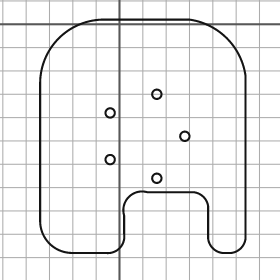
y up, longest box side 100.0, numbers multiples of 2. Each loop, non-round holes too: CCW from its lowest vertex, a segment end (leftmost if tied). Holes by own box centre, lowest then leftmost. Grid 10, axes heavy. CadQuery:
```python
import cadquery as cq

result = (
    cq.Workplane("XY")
    .moveTo(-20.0, -98.0)
    .lineTo(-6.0, -98.0)
    .threePointArc((0.0, -96.0), (2.0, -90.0))
    .lineTo(2.0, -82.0)
    .threePointArc((4.0, -74.0), (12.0, -72.0))
    .lineTo(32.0, -72.0)
    .threePointArc((36.0, -74.0), (38.0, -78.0))
    .lineTo(38.0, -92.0)
    .threePointArc((40.0, -96.0), (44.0, -98.0))
    .lineTo(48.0, -98.0)
    .threePointArc((52.0, -96.0), (54.0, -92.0))
    .lineTo(54.0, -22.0)
    .threePointArc((46.0, -6.0), (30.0, 2.0))
    .lineTo(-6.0, 2.0)
    .threePointArc((-26.0, -6.0), (-34.0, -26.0))
    .lineTo(-34.0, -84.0)
    .threePointArc((-30.0, -94.0), (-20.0, -98.0))
    .close()
    .moveTo(16.0, -66.0)
    .circle(2.0)
    .moveTo(-4.0, -58.0)
    .circle(2.0)
    .moveTo(28.0, -48.0)
    .circle(2.0)
    .moveTo(-4.0, -38.0)
    .circle(2.0)
    .moveTo(16.0, -30.0)
    .circle(2.0)
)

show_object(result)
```